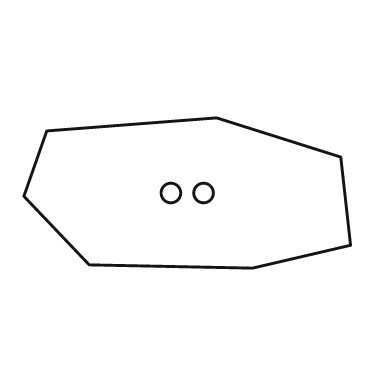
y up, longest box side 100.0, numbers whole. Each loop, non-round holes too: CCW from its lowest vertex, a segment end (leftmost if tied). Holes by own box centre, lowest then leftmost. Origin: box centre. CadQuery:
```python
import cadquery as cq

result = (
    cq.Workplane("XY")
    .moveTo(20.0, -23.0)
    .lineTo(50.0, -16.0)
    .lineTo(47.0, 11.0)
    .lineTo(9.0, 23.0)
    .lineTo(-43.0, 19.0)
    .lineTo(-50.0, -1.0)
    .lineTo(-30.0, -22.0)
    .close()
    .moveTo(-5.0, 0.0)
    .circle(3.0)
    .moveTo(5.0, 0.0)
    .circle(3.0)
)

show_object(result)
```